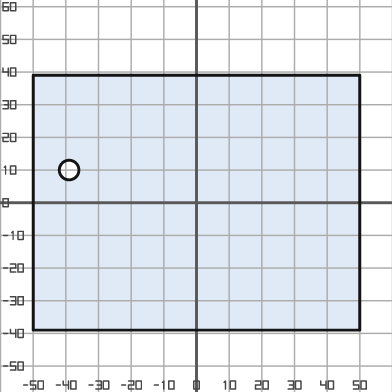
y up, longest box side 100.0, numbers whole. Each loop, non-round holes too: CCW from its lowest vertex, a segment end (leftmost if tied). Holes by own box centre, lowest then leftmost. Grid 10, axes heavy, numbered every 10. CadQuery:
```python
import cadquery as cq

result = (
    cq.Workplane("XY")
    .moveTo(-50.0, -39.0)
    .lineTo(50.0, -39.0)
    .lineTo(50.0, 39.0)
    .lineTo(-50.0, 39.0)
    .close()
    .moveTo(-39.0, 10.0)
    .circle(3.0)
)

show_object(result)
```